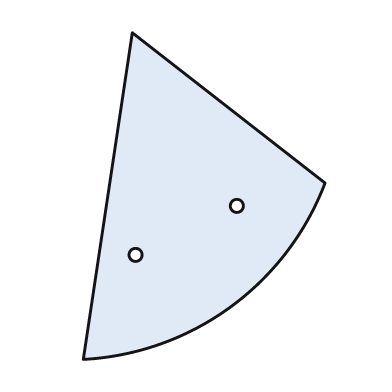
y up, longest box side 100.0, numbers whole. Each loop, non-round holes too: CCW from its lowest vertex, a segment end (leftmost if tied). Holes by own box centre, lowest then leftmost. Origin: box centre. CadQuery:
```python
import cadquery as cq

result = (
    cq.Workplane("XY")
    .moveTo(-37.0, -50.0)
    .threePointArc((8.0, -34.0), (37.0, 4.0))
    .lineTo(-22.0, 50.0)
    .close()
    .moveTo(-21.0, -18.0)
    .circle(2.0)
    .moveTo(10.0, -3.0)
    .circle(2.0)
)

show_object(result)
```